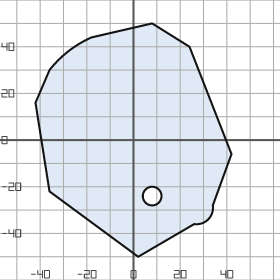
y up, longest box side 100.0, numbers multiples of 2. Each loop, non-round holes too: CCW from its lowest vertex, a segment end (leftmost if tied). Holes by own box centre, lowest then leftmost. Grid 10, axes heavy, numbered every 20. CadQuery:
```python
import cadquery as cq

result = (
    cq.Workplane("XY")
    .moveTo(2.0, -50.0)
    .lineTo(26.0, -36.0)
    .threePointArc((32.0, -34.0), (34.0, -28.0))
    .lineTo(42.0, -6.0)
    .lineTo(24.0, 40.0)
    .lineTo(8.0, 50.0)
    .lineTo(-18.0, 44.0)
    .threePointArc((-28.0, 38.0), (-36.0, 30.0))
    .lineTo(-42.0, 16.0)
    .lineTo(-36.0, -22.0)
    .close()
    .moveTo(8.0, -24.0)
    .circle(4.0)
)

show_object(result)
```